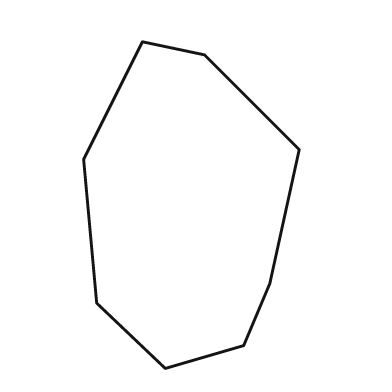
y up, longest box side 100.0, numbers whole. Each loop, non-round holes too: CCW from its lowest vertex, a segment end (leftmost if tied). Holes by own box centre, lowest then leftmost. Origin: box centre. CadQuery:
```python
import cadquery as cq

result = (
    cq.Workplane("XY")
    .moveTo(-8.0, -50.0)
    .lineTo(16.0, -43.0)
    .lineTo(24.0, -24.0)
    .lineTo(33.0, 17.0)
    .lineTo(4.0, 46.0)
    .lineTo(-15.0, 50.0)
    .lineTo(-33.0, 14.0)
    .lineTo(-29.0, -30.0)
    .close()
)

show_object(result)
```